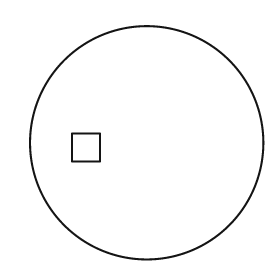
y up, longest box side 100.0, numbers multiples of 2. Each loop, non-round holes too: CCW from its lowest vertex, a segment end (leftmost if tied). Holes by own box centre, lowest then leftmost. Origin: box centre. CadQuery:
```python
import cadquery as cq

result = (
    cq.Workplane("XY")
    .moveTo(0.0, 0.0)
    .circle(50.0)
    .moveTo(-32.0, -8.0)
    .lineTo(-20.0, -8.0)
    .lineTo(-20.0, 4.0)
    .lineTo(-32.0, 4.0)
    .close()
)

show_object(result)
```